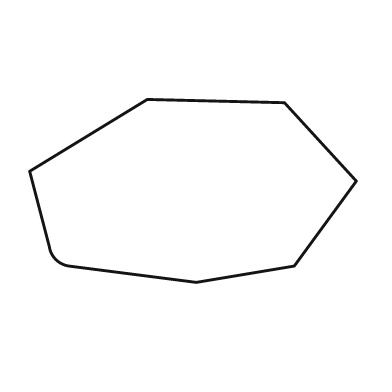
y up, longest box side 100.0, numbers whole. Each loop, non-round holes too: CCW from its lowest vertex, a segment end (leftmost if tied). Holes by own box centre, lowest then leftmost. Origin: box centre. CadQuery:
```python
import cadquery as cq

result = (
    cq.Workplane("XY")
    .moveTo(1.0, -28.0)
    .lineTo(31.0, -23.0)
    .lineTo(50.0, 3.0)
    .lineTo(28.0, 27.0)
    .lineTo(-14.0, 28.0)
    .lineTo(-50.0, 6.0)
    .lineTo(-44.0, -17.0)
    .threePointArc((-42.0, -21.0), (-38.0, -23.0))
    .close()
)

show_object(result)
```